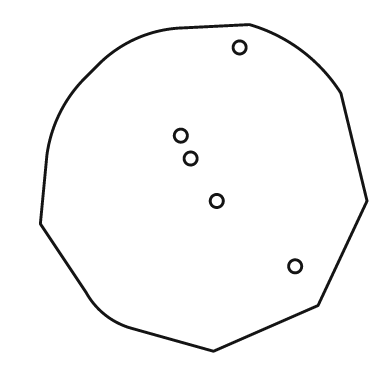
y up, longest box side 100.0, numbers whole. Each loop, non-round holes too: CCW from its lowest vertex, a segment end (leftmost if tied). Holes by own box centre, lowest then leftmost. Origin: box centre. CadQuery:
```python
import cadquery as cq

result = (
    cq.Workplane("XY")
    .moveTo(3.0, -50.0)
    .lineTo(35.0, -36.0)
    .lineTo(50.0, -4.0)
    .lineTo(42.0, 29.0)
    .threePointArc((30.0, 42.0), (14.0, 50.0))
    .lineTo(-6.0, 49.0)
    .threePointArc((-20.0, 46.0), (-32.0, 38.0))
    .lineTo(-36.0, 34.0)
    .threePointArc((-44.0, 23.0), (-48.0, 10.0))
    .lineTo(-50.0, -11.0)
    .lineTo(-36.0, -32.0)
    .threePointArc((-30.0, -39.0), (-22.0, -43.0))
    .close()
    .moveTo(28.0, -24.0)
    .circle(2.0)
    .moveTo(4.0, -4.0)
    .circle(2.0)
    .moveTo(-4.0, 9.0)
    .circle(2.0)
    .moveTo(-7.0, 16.0)
    .circle(2.0)
    .moveTo(11.0, 43.0)
    .circle(2.0)
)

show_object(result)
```